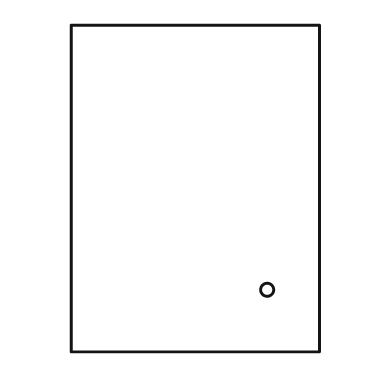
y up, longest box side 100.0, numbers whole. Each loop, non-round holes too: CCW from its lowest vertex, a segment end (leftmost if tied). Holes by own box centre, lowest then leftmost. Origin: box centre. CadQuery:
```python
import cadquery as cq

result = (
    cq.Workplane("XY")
    .moveTo(-38.0, -50.0)
    .lineTo(38.0, -50.0)
    .lineTo(38.0, 50.0)
    .lineTo(-38.0, 50.0)
    .close()
    .moveTo(22.0, -31.0)
    .circle(2.0)
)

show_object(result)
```